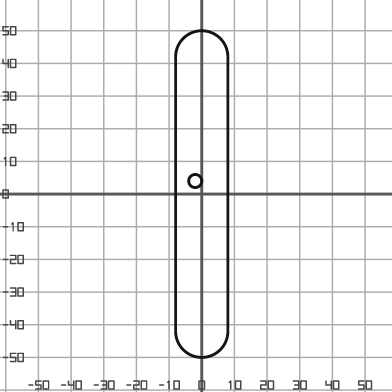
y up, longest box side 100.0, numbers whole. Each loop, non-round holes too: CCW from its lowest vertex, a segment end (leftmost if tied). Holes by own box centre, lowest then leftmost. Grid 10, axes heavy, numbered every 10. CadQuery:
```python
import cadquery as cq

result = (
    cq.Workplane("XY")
    .moveTo(-8.0, -42.0)
    .threePointArc((0.0, -50.0), (8.0, -42.0))
    .lineTo(8.0, 42.0)
    .threePointArc((0.0, 50.0), (-8.0, 42.0))
    .close()
    .moveTo(-2.0, 4.0)
    .circle(2.0)
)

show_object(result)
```